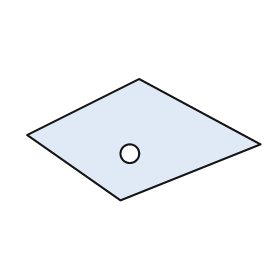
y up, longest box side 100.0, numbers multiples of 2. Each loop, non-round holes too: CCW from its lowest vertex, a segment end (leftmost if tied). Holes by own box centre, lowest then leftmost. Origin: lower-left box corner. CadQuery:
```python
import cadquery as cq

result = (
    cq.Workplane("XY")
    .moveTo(40.0, 0.0)
    .lineTo(100.0, 24.0)
    .lineTo(48.0, 52.0)
    .lineTo(0.0, 28.0)
    .close()
    .moveTo(44.0, 20.0)
    .circle(4.0)
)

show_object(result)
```